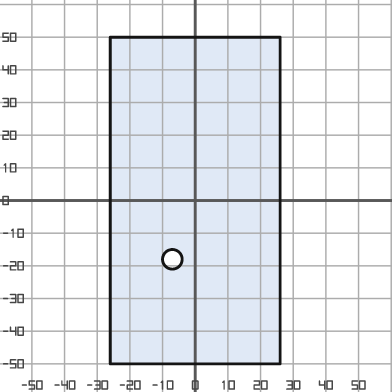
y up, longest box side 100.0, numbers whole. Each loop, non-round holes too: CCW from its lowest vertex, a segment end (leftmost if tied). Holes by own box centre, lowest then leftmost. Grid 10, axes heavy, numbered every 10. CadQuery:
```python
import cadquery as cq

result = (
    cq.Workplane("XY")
    .moveTo(-26.0, -50.0)
    .lineTo(26.0, -50.0)
    .lineTo(26.0, 50.0)
    .lineTo(-26.0, 50.0)
    .close()
    .moveTo(-7.0, -18.0)
    .circle(3.0)
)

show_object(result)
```